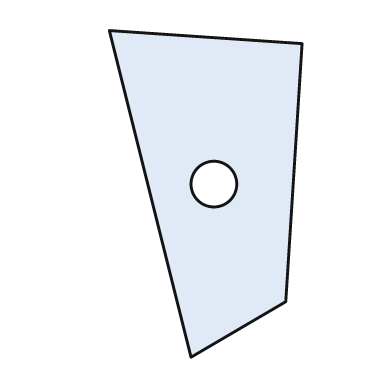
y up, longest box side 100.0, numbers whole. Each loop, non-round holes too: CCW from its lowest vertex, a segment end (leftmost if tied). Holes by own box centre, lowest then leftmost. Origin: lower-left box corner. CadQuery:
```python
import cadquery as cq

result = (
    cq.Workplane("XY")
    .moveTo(25.0, 0.0)
    .lineTo(54.0, 17.0)
    .lineTo(59.0, 96.0)
    .lineTo(0.0, 100.0)
    .close()
    .moveTo(32.0, 53.0)
    .circle(7.0)
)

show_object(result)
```